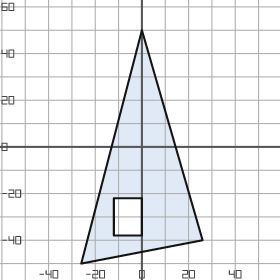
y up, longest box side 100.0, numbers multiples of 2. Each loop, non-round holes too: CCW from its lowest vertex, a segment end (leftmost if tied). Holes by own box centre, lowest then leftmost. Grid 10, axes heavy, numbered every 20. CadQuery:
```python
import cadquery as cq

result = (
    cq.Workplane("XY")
    .moveTo(-26.0, -50.0)
    .lineTo(26.0, -40.0)
    .lineTo(0.0, 50.0)
    .close()
    .moveTo(-12.0, -38.0)
    .lineTo(0.0, -38.0)
    .lineTo(0.0, -22.0)
    .lineTo(-12.0, -22.0)
    .close()
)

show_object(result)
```